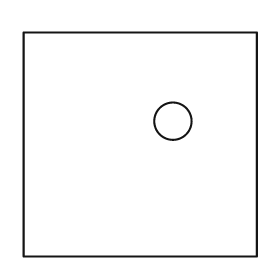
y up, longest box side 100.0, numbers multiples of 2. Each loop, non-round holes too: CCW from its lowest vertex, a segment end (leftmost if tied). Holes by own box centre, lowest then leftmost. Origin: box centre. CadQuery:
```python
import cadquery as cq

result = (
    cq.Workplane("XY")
    .moveTo(-50.0, -48.0)
    .lineTo(50.0, -48.0)
    .lineTo(50.0, 48.0)
    .lineTo(-50.0, 48.0)
    .close()
    .moveTo(14.0, 10.0)
    .circle(8.0)
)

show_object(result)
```